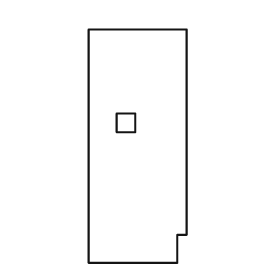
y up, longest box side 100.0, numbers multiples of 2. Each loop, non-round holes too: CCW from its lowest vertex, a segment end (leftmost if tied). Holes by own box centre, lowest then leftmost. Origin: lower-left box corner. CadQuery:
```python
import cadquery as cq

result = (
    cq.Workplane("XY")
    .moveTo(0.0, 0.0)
    .lineTo(38.0, 0.0)
    .lineTo(38.0, 12.0)
    .lineTo(42.0, 12.0)
    .lineTo(42.0, 100.0)
    .lineTo(0.0, 100.0)
    .close()
    .moveTo(12.0, 56.0)
    .lineTo(20.0, 56.0)
    .lineTo(20.0, 64.0)
    .lineTo(12.0, 64.0)
    .close()
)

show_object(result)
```